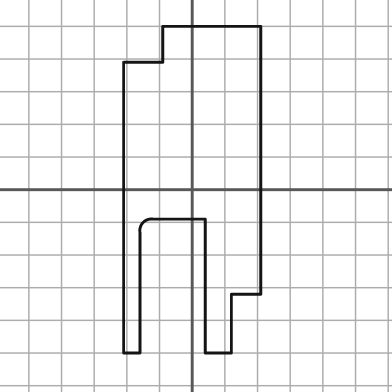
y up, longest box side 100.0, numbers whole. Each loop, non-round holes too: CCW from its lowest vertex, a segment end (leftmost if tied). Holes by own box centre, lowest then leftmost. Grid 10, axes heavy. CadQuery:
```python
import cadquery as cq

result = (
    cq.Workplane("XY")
    .moveTo(-21.0, -50.0)
    .lineTo(-16.0, -50.0)
    .lineTo(-16.0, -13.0)
    .threePointArc((-15.0, -10.0), (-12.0, -9.0))
    .lineTo(4.0, -9.0)
    .lineTo(4.0, -50.0)
    .lineTo(12.0, -50.0)
    .lineTo(12.0, -32.0)
    .lineTo(21.0, -32.0)
    .lineTo(21.0, 50.0)
    .lineTo(-9.0, 50.0)
    .lineTo(-9.0, 39.0)
    .lineTo(-21.0, 39.0)
    .close()
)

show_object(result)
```